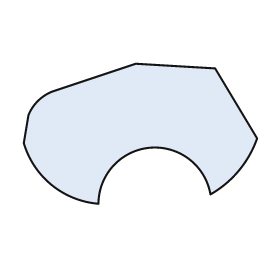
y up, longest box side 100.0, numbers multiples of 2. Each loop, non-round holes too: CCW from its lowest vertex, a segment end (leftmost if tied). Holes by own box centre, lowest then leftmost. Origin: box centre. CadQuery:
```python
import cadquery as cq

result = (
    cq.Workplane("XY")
    .moveTo(-18.0, -30.0)
    .threePointArc((4.0, -6.0), (30.0, -26.0))
    .threePointArc((42.0, -16.0), (50.0, -2.0))
    .lineTo(32.0, 28.0)
    .lineTo(-2.0, 30.0)
    .lineTo(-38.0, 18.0)
    .threePointArc((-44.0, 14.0), (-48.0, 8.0))
    .lineTo(-50.0, -4.0)
    .threePointArc((-38.0, -22.0), (-18.0, -30.0))
    .close()
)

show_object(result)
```